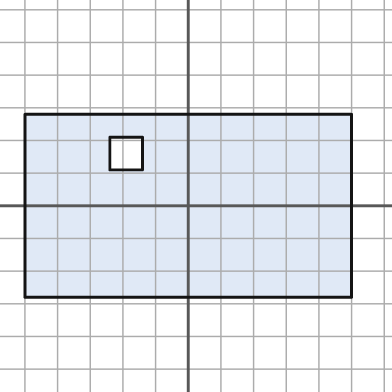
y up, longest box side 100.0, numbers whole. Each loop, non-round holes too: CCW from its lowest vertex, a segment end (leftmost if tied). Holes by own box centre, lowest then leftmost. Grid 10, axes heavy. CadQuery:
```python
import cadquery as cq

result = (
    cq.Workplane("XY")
    .moveTo(-50.0, -28.0)
    .lineTo(50.0, -28.0)
    .lineTo(50.0, 28.0)
    .lineTo(-50.0, 28.0)
    .close()
    .moveTo(-24.0, 11.0)
    .lineTo(-14.0, 11.0)
    .lineTo(-14.0, 21.0)
    .lineTo(-24.0, 21.0)
    .close()
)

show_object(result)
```